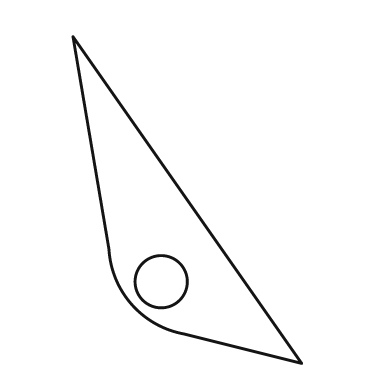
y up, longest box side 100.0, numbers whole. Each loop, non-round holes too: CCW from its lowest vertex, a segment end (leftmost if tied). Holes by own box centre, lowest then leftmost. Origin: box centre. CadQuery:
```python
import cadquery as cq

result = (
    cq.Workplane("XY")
    .moveTo(35.0, -50.0)
    .lineTo(-35.0, 50.0)
    .lineTo(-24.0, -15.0)
    .threePointArc((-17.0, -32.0), (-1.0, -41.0))
    .close()
    .moveTo(-8.0, -25.0)
    .circle(8.0)
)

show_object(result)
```